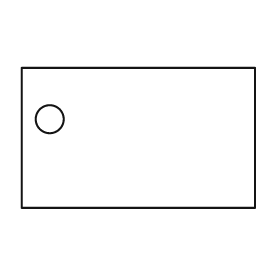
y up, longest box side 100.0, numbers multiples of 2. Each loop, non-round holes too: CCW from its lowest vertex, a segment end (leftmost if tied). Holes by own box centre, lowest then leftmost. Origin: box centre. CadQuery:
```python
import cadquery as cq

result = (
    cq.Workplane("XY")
    .moveTo(-50.0, -30.0)
    .lineTo(50.0, -30.0)
    .lineTo(50.0, 30.0)
    .lineTo(-50.0, 30.0)
    .close()
    .moveTo(-38.0, 8.0)
    .circle(6.0)
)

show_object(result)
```